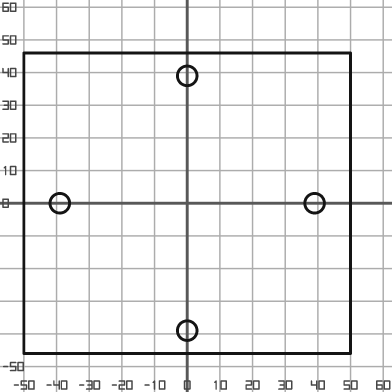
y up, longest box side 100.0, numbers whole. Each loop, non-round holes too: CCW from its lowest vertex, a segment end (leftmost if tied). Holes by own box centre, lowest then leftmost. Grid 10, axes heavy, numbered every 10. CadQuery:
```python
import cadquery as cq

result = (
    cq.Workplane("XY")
    .moveTo(-50.0, -46.0)
    .lineTo(50.0, -46.0)
    .lineTo(50.0, 46.0)
    .lineTo(-50.0, 46.0)
    .close()
    .moveTo(0.0, -39.0)
    .circle(3.0)
    .moveTo(-39.0, 0.0)
    .circle(3.0)
    .moveTo(39.0, 0.0)
    .circle(3.0)
    .moveTo(0.0, 39.0)
    .circle(3.0)
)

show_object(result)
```